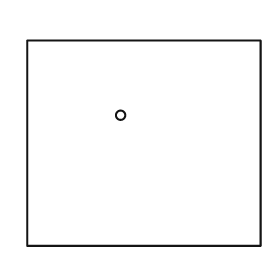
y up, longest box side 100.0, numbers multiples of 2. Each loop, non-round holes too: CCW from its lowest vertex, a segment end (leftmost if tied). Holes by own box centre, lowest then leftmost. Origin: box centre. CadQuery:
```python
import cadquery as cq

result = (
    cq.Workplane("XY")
    .moveTo(-50.0, -44.0)
    .lineTo(50.0, -44.0)
    .lineTo(50.0, 44.0)
    .lineTo(-50.0, 44.0)
    .close()
    .moveTo(-10.0, 12.0)
    .circle(2.0)
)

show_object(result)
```